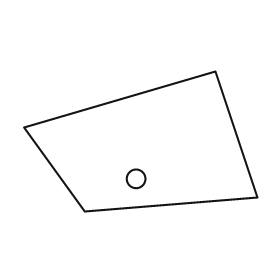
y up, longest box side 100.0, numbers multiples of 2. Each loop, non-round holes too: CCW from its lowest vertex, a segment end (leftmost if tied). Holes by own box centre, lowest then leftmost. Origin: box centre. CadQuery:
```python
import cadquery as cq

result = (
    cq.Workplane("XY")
    .moveTo(-24.0, -30.0)
    .lineTo(50.0, -24.0)
    .lineTo(32.0, 30.0)
    .lineTo(-50.0, 6.0)
    .close()
    .moveTo(-2.0, -16.0)
    .circle(4.0)
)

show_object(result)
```